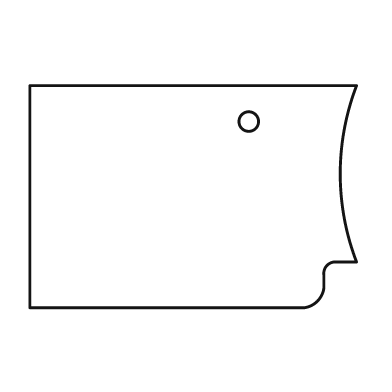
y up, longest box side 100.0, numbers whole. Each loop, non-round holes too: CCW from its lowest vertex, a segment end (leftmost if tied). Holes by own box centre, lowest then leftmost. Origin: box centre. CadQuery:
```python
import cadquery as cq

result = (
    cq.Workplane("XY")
    .moveTo(-50.0, -34.0)
    .lineTo(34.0, -34.0)
    .threePointArc((38.0, -32.0), (40.0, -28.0))
    .lineTo(40.0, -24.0)
    .threePointArc((41.0, -21.0), (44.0, -20.0))
    .lineTo(50.0, -20.0)
    .threePointArc((45.0, 7.0), (50.0, 34.0))
    .lineTo(-50.0, 34.0)
    .close()
    .moveTo(17.0, 23.0)
    .circle(3.0)
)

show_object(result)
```